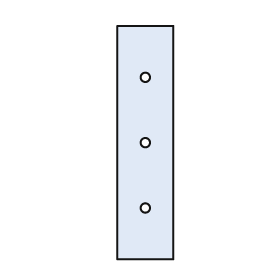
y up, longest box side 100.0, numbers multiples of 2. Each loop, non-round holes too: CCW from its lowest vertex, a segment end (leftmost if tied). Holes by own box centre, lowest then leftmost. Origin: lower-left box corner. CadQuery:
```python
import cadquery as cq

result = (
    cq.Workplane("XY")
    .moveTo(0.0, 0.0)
    .lineTo(24.0, 0.0)
    .lineTo(24.0, 100.0)
    .lineTo(0.0, 100.0)
    .close()
    .moveTo(12.0, 22.0)
    .circle(2.0)
    .moveTo(12.0, 50.0)
    .circle(2.0)
    .moveTo(12.0, 78.0)
    .circle(2.0)
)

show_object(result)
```